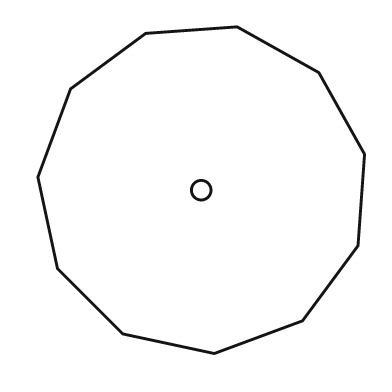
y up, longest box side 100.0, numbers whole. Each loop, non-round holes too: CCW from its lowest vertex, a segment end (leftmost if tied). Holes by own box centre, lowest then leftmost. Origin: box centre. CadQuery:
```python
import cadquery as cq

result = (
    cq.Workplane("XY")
    .moveTo(4.0, -50.0)
    .lineTo(31.0, -40.0)
    .lineTo(48.0, -17.0)
    .lineTo(50.0, 11.0)
    .lineTo(36.0, 36.0)
    .lineTo(11.0, 50.0)
    .lineTo(-17.0, 48.0)
    .lineTo(-40.0, 31.0)
    .lineTo(-50.0, 4.0)
    .lineTo(-44.0, -24.0)
    .lineTo(-24.0, -44.0)
    .close()
    .moveTo(0.0, 0.0)
    .circle(3.0)
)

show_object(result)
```